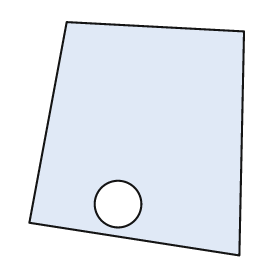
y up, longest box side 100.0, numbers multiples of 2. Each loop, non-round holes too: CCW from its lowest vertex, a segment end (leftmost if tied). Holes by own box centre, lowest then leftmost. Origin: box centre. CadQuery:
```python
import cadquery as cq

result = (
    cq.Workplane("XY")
    .moveTo(44.0, -50.0)
    .lineTo(46.0, 46.0)
    .lineTo(-30.0, 50.0)
    .lineTo(-46.0, -36.0)
    .close()
    .moveTo(-8.0, -28.0)
    .circle(10.0)
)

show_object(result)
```